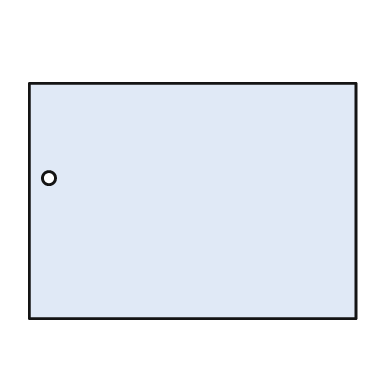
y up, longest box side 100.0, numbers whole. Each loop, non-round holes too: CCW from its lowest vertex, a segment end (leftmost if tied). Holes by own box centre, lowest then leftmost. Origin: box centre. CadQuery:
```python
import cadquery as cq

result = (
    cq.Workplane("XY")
    .moveTo(-50.0, -36.0)
    .lineTo(50.0, -36.0)
    .lineTo(50.0, 36.0)
    .lineTo(-50.0, 36.0)
    .close()
    .moveTo(-44.0, 7.0)
    .circle(2.0)
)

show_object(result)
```